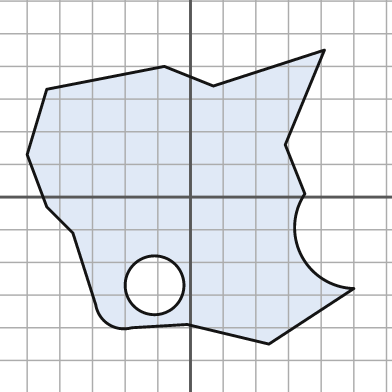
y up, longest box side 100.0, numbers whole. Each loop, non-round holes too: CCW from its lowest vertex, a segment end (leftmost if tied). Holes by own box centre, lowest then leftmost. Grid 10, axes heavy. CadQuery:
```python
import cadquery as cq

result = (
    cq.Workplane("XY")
    .moveTo(24.0, -45.0)
    .lineTo(50.0, -28.0)
    .threePointArc((34.0, -18.0), (35.0, 1.0))
    .lineTo(29.0, 16.0)
    .lineTo(41.0, 45.0)
    .lineTo(7.0, 34.0)
    .lineTo(-8.0, 40.0)
    .lineTo(-44.0, 33.0)
    .lineTo(-50.0, 13.0)
    .lineTo(-44.0, -3.0)
    .lineTo(-36.0, -11.0)
    .lineTo(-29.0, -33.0)
    .threePointArc((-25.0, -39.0), (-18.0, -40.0))
    .lineTo(-1.0, -39.0)
    .close()
    .moveTo(-11.0, -27.0)
    .circle(9.0)
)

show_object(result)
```